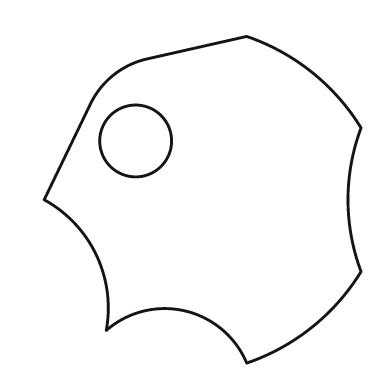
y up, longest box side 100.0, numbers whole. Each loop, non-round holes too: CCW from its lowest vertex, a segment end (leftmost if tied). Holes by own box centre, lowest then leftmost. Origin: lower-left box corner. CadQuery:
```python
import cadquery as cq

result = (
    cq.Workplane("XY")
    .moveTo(62.0, 0.0)
    .threePointArc((82.0, 11.0), (97.0, 28.0))
    .threePointArc((93.0, 50.0), (97.0, 72.0))
    .threePointArc((82.0, 89.0), (62.0, 100.0))
    .lineTo(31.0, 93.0)
    .threePointArc((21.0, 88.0), (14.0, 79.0))
    .lineTo(0.0, 50.0)
    .threePointArc((16.0, 33.0), (19.0, 10.0))
    .threePointArc((43.0, 16.0), (62.0, 0.0))
    .close()
    .moveTo(28.0, 68.0)
    .circle(11.0)
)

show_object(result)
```